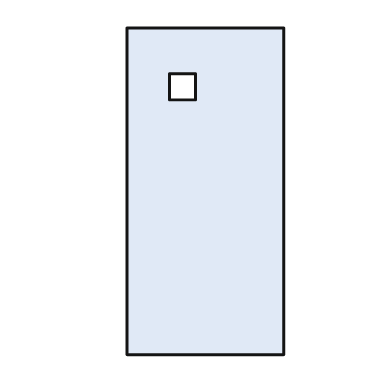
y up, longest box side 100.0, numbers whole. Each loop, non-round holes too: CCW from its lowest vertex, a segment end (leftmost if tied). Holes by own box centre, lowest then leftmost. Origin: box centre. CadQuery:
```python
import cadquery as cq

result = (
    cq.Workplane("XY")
    .moveTo(-24.0, -50.0)
    .lineTo(24.0, -50.0)
    .lineTo(24.0, 50.0)
    .lineTo(-24.0, 50.0)
    .close()
    .moveTo(-11.0, 28.0)
    .lineTo(-3.0, 28.0)
    .lineTo(-3.0, 36.0)
    .lineTo(-11.0, 36.0)
    .close()
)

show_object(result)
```